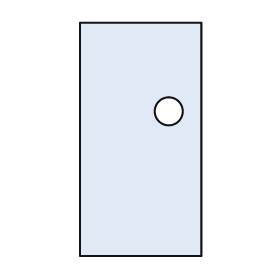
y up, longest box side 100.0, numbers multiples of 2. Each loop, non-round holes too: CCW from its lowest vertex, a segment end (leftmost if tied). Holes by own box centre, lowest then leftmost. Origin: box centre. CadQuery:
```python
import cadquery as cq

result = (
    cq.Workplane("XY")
    .moveTo(-26.0, -50.0)
    .lineTo(26.0, -50.0)
    .lineTo(26.0, 50.0)
    .lineTo(-26.0, 50.0)
    .close()
    .moveTo(12.0, 12.0)
    .circle(6.0)
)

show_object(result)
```